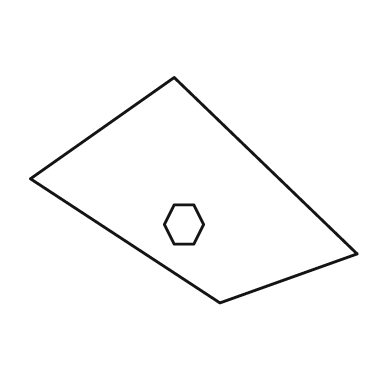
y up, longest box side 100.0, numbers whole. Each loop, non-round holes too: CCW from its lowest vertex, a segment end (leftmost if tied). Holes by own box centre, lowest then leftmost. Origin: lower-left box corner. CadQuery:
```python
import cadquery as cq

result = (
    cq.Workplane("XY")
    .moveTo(58.0, 0.0)
    .lineTo(100.0, 15.0)
    .lineTo(44.0, 69.0)
    .lineTo(0.0, 38.0)
    .close()
    .moveTo(44.0, 18.0)
    .lineTo(50.0, 18.0)
    .lineTo(53.0, 24.0)
    .lineTo(50.0, 30.0)
    .lineTo(44.0, 30.0)
    .lineTo(41.0, 24.0)
    .close()
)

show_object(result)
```